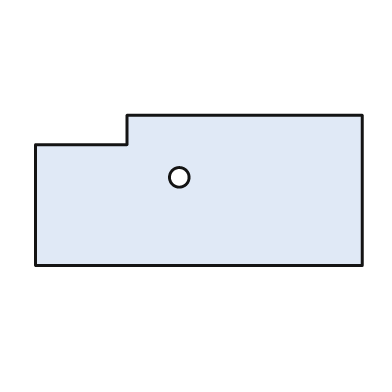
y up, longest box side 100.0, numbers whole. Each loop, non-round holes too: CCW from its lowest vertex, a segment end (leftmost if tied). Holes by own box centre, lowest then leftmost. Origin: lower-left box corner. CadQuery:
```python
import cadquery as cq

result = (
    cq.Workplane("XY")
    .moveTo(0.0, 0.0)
    .lineTo(100.0, 0.0)
    .lineTo(100.0, 46.0)
    .lineTo(28.0, 46.0)
    .lineTo(28.0, 37.0)
    .lineTo(0.0, 37.0)
    .close()
    .moveTo(44.0, 27.0)
    .circle(3.0)
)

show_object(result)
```